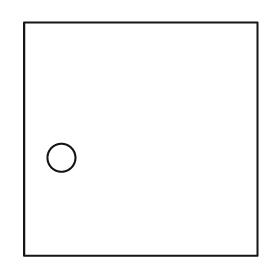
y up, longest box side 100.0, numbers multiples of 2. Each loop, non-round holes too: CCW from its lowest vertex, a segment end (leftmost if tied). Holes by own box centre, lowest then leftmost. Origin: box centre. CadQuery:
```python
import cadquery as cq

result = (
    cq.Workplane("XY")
    .moveTo(-50.0, -50.0)
    .lineTo(50.0, -50.0)
    .lineTo(50.0, 50.0)
    .lineTo(-50.0, 50.0)
    .close()
    .moveTo(-34.0, -8.0)
    .circle(6.0)
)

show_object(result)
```